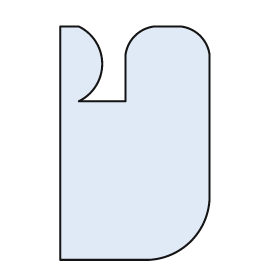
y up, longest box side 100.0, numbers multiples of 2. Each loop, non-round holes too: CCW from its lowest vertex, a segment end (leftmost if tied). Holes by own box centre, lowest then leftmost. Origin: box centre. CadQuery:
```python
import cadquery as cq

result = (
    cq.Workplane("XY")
    .moveTo(-32.0, -50.0)
    .lineTo(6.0, -50.0)
    .threePointArc((24.0, -42.0), (32.0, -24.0))
    .lineTo(32.0, 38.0)
    .threePointArc((28.0, 46.0), (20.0, 50.0))
    .lineTo(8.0, 50.0)
    .threePointArc((0.0, 46.0), (-4.0, 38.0))
    .lineTo(-4.0, 18.0)
    .lineTo(-24.0, 18.0)
    .threePointArc((-14.0, 34.0), (-24.0, 50.0))
    .lineTo(-32.0, 50.0)
    .close()
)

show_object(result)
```